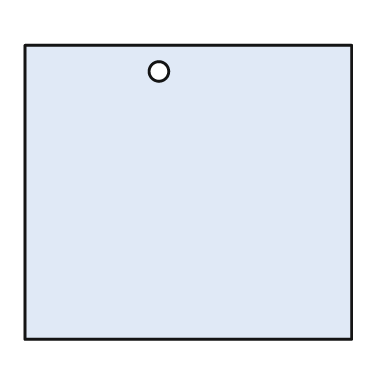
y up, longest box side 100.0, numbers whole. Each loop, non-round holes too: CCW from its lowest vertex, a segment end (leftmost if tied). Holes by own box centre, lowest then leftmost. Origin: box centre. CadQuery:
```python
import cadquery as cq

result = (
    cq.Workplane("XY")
    .moveTo(-50.0, -45.0)
    .lineTo(50.0, -45.0)
    .lineTo(50.0, 45.0)
    .lineTo(-50.0, 45.0)
    .close()
    .moveTo(-9.0, 37.0)
    .circle(3.0)
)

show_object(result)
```